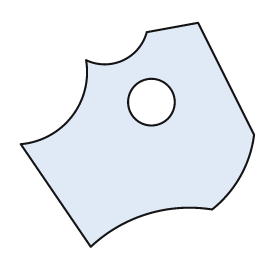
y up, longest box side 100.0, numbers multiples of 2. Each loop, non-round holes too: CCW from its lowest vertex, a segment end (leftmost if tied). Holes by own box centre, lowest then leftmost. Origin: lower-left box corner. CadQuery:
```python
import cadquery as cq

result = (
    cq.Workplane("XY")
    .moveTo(30.0, 0.0)
    .threePointArc((54.0, 14.0), (82.0, 16.0))
    .threePointArc((94.0, 30.0), (100.0, 48.0))
    .lineTo(76.0, 96.0)
    .lineTo(54.0, 92.0)
    .threePointArc((44.0, 80.0), (28.0, 80.0))
    .threePointArc((22.0, 56.0), (0.0, 44.0))
    .close()
    .moveTo(56.0, 62.0)
    .circle(10.0)
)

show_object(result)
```